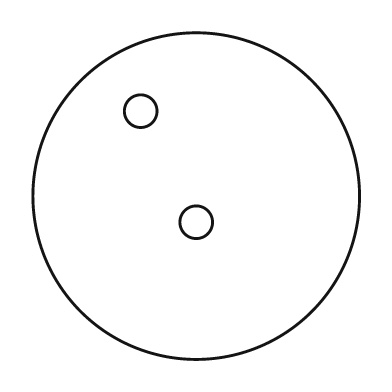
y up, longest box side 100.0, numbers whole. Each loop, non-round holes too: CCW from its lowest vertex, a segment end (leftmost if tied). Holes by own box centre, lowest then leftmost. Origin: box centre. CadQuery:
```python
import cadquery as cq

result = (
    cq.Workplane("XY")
    .moveTo(0.0, 0.0)
    .circle(50.0)
    .moveTo(0.0, -8.0)
    .circle(5.0)
    .moveTo(-17.0, 26.0)
    .circle(5.0)
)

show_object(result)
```